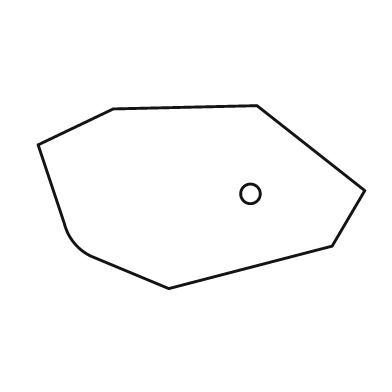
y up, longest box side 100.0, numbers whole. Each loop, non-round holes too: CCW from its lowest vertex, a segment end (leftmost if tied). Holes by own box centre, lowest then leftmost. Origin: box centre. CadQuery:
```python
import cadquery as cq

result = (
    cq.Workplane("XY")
    .moveTo(-10.0, -28.0)
    .lineTo(40.0, -15.0)
    .lineTo(50.0, 2.0)
    .lineTo(17.0, 28.0)
    .lineTo(-27.0, 27.0)
    .lineTo(-50.0, 16.0)
    .lineTo(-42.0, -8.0)
    .threePointArc((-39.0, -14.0), (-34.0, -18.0))
    .close()
    .moveTo(15.0, 1.0)
    .circle(3.0)
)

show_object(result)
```